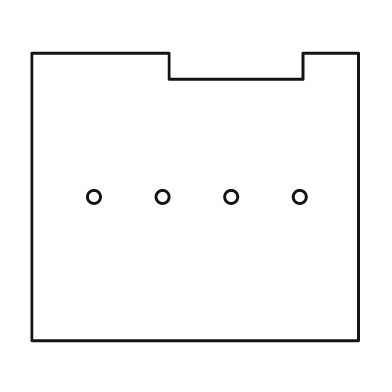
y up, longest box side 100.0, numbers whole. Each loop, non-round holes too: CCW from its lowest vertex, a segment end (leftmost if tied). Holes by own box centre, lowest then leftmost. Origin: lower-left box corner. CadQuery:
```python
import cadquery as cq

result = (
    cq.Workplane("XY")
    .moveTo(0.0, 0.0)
    .lineTo(100.0, 0.0)
    .lineTo(100.0, 88.0)
    .lineTo(83.0, 88.0)
    .lineTo(83.0, 80.0)
    .lineTo(42.0, 80.0)
    .lineTo(42.0, 88.0)
    .lineTo(0.0, 88.0)
    .close()
    .moveTo(19.0, 44.0)
    .circle(2.0)
    .moveTo(40.0, 44.0)
    .circle(2.0)
    .moveTo(61.0, 44.0)
    .circle(2.0)
    .moveTo(82.0, 44.0)
    .circle(2.0)
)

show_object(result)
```